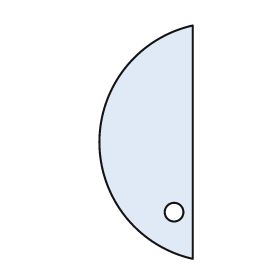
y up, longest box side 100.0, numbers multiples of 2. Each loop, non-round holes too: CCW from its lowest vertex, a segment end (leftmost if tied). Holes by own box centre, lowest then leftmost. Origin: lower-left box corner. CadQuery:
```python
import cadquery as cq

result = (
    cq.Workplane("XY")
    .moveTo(40.0, 0.0)
    .lineTo(40.0, 100.0)
    .threePointArc((0.0, 50.0), (40.0, 0.0))
    .close()
    .moveTo(32.0, 20.0)
    .circle(4.0)
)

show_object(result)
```